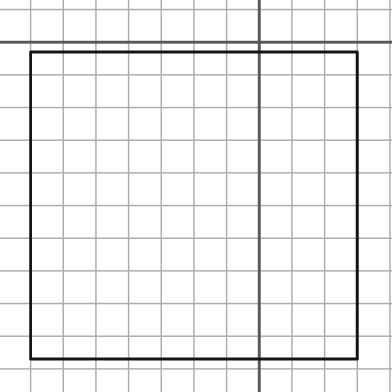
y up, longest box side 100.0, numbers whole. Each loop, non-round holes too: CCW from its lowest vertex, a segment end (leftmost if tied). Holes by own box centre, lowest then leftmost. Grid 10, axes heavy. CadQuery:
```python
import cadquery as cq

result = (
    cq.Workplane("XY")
    .moveTo(-70.0, -97.0)
    .lineTo(30.0, -97.0)
    .lineTo(30.0, -3.0)
    .lineTo(-70.0, -3.0)
    .close()
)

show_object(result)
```